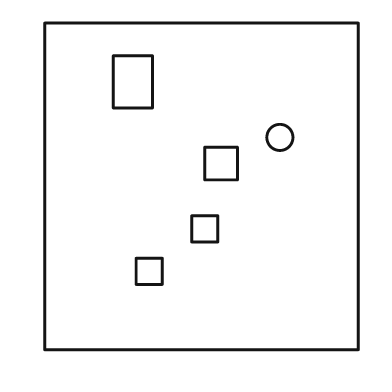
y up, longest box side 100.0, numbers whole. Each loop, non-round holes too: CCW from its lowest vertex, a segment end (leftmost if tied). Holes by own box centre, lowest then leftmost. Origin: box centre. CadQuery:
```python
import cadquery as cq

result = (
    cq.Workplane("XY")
    .moveTo(-48.0, -50.0)
    .lineTo(48.0, -50.0)
    .lineTo(48.0, 50.0)
    .lineTo(-48.0, 50.0)
    .close()
    .moveTo(-20.0, -30.0)
    .lineTo(-12.0, -30.0)
    .lineTo(-12.0, -22.0)
    .lineTo(-20.0, -22.0)
    .close()
    .moveTo(-3.0, -17.0)
    .lineTo(5.0, -17.0)
    .lineTo(5.0, -9.0)
    .lineTo(-3.0, -9.0)
    .close()
    .moveTo(1.0, 2.0)
    .lineTo(11.0, 2.0)
    .lineTo(11.0, 12.0)
    .lineTo(1.0, 12.0)
    .close()
    .moveTo(24.0, 15.0)
    .circle(4.0)
    .moveTo(-27.0, 24.0)
    .lineTo(-15.0, 24.0)
    .lineTo(-15.0, 40.0)
    .lineTo(-27.0, 40.0)
    .close()
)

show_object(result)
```